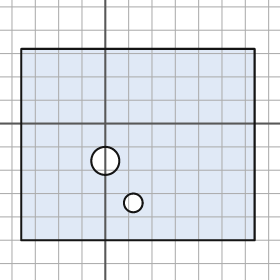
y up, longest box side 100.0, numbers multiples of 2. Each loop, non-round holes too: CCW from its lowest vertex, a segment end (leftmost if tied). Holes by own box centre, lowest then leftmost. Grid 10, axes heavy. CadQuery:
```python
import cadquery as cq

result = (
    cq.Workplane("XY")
    .moveTo(-36.0, -50.0)
    .lineTo(64.0, -50.0)
    .lineTo(64.0, 32.0)
    .lineTo(-36.0, 32.0)
    .close()
    .moveTo(12.0, -34.0)
    .circle(4.0)
    .moveTo(0.0, -16.0)
    .circle(6.0)
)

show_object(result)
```